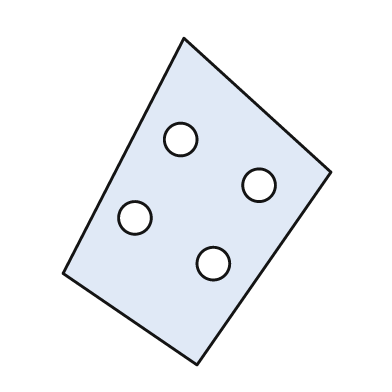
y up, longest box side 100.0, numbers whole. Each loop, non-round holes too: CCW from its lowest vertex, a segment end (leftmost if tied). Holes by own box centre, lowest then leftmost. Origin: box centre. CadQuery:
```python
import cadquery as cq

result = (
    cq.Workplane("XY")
    .moveTo(0.0, -50.0)
    .lineTo(41.0, 9.0)
    .lineTo(-4.0, 50.0)
    .lineTo(-41.0, -22.0)
    .close()
    .moveTo(5.0, -19.0)
    .circle(5.0)
    .moveTo(-19.0, -5.0)
    .circle(5.0)
    .moveTo(19.0, 5.0)
    .circle(5.0)
    .moveTo(-5.0, 19.0)
    .circle(5.0)
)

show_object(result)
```